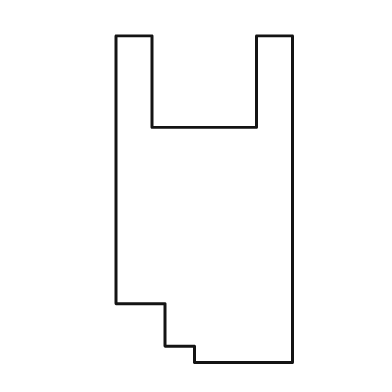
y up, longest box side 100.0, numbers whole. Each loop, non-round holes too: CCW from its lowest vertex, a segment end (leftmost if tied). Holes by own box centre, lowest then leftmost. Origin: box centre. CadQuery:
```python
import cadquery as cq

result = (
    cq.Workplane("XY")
    .moveTo(-3.0, -50.0)
    .lineTo(27.0, -50.0)
    .lineTo(27.0, 50.0)
    .lineTo(16.0, 50.0)
    .lineTo(16.0, 22.0)
    .lineTo(-16.0, 22.0)
    .lineTo(-16.0, 50.0)
    .lineTo(-27.0, 50.0)
    .lineTo(-27.0, -32.0)
    .lineTo(-12.0, -32.0)
    .lineTo(-12.0, -45.0)
    .lineTo(-3.0, -45.0)
    .close()
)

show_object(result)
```